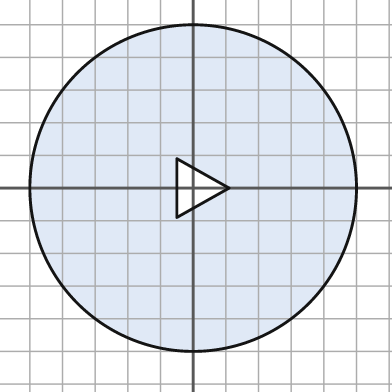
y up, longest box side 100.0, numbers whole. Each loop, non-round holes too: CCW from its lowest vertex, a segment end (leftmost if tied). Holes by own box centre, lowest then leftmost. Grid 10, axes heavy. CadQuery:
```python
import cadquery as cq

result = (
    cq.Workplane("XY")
    .moveTo(0.0, 0.0)
    .circle(50.0)
    .moveTo(-5.0, -9.0)
    .lineTo(11.0, 0.0)
    .lineTo(-5.0, 9.0)
    .close()
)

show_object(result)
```